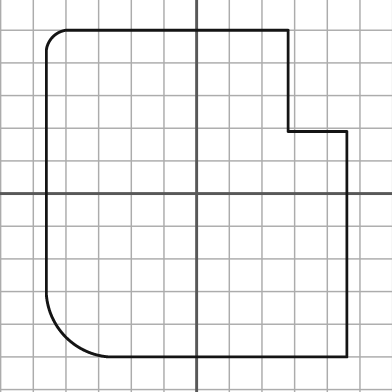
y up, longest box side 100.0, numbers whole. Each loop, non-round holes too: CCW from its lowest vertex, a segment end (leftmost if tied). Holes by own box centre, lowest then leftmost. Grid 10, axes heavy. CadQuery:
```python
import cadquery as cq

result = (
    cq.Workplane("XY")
    .moveTo(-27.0, -50.0)
    .lineTo(46.0, -50.0)
    .lineTo(46.0, 19.0)
    .lineTo(28.0, 19.0)
    .lineTo(28.0, 50.0)
    .lineTo(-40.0, 50.0)
    .threePointArc((-44.0, 48.0), (-46.0, 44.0))
    .lineTo(-46.0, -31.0)
    .threePointArc((-40.0, -44.0), (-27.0, -50.0))
    .close()
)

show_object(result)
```